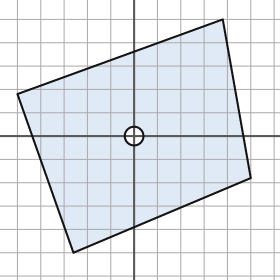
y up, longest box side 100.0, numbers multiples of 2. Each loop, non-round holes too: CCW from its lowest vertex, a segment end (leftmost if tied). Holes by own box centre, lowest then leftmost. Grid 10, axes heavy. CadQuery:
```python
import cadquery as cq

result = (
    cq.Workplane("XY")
    .moveTo(-26.0, -50.0)
    .lineTo(50.0, -18.0)
    .lineTo(38.0, 50.0)
    .lineTo(-50.0, 18.0)
    .close()
    .moveTo(0.0, 0.0)
    .circle(4.0)
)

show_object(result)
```